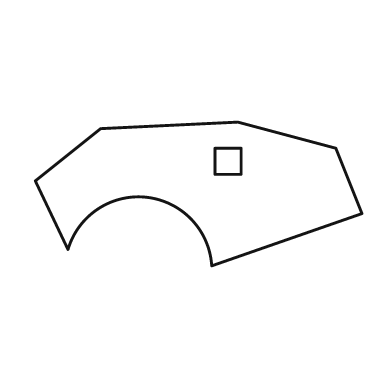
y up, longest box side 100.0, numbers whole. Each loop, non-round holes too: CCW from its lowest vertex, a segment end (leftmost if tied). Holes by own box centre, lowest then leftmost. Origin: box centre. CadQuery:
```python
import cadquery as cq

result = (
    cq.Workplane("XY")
    .moveTo(4.0, -22.0)
    .lineTo(50.0, -6.0)
    .lineTo(42.0, 14.0)
    .lineTo(12.0, 22.0)
    .lineTo(-30.0, 20.0)
    .lineTo(-50.0, 4.0)
    .lineTo(-40.0, -17.0)
    .threePointArc((-16.0, -1.0), (4.0, -22.0))
    .close()
    .moveTo(5.0, 6.0)
    .lineTo(13.0, 6.0)
    .lineTo(13.0, 14.0)
    .lineTo(5.0, 14.0)
    .close()
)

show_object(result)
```